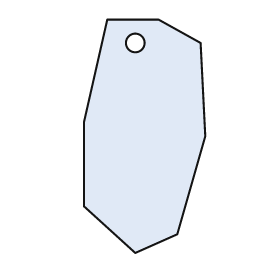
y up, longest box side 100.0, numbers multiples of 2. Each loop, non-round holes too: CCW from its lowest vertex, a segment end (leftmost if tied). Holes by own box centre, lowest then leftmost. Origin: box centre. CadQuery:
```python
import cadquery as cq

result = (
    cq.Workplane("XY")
    .moveTo(-4.0, -50.0)
    .lineTo(14.0, -42.0)
    .lineTo(26.0, 0.0)
    .lineTo(24.0, 40.0)
    .lineTo(6.0, 50.0)
    .lineTo(-16.0, 50.0)
    .lineTo(-26.0, 6.0)
    .lineTo(-26.0, -30.0)
    .close()
    .moveTo(-4.0, 40.0)
    .circle(4.0)
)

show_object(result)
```